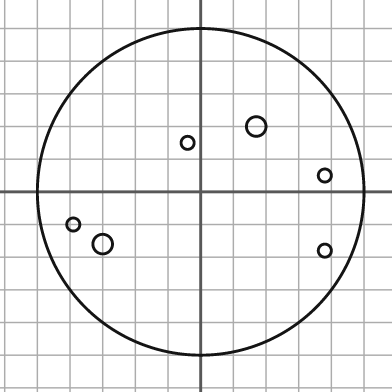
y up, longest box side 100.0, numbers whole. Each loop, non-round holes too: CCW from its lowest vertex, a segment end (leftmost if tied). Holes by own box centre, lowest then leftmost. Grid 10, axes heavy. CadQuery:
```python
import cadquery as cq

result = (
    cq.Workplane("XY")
    .moveTo(0.0, 0.0)
    .circle(50.0)
    .moveTo(38.0, -18.0)
    .circle(2.0)
    .moveTo(-30.0, -16.0)
    .circle(3.0)
    .moveTo(-39.0, -10.0)
    .circle(2.0)
    .moveTo(38.0, 5.0)
    .circle(2.0)
    .moveTo(-4.0, 15.0)
    .circle(2.0)
    .moveTo(17.0, 20.0)
    .circle(3.0)
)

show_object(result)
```